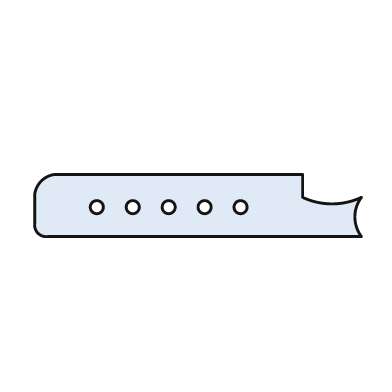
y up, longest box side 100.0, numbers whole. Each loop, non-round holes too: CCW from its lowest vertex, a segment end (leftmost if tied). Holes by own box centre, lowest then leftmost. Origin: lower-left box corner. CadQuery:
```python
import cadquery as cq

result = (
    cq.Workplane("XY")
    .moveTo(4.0, 0.0)
    .lineTo(100.0, 0.0)
    .threePointArc((98.0, 6.0), (100.0, 12.0))
    .threePointArc((91.0, 10.0), (82.0, 12.0))
    .lineTo(82.0, 19.0)
    .lineTo(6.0, 19.0)
    .threePointArc((2.0, 17.0), (0.0, 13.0))
    .lineTo(0.0, 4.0)
    .threePointArc((1.0, 1.0), (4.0, 0.0))
    .close()
    .moveTo(19.0, 9.0)
    .circle(2.0)
    .moveTo(30.0, 9.0)
    .circle(2.0)
    .moveTo(41.0, 9.0)
    .circle(2.0)
    .moveTo(52.0, 9.0)
    .circle(2.0)
    .moveTo(63.0, 9.0)
    .circle(2.0)
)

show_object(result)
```